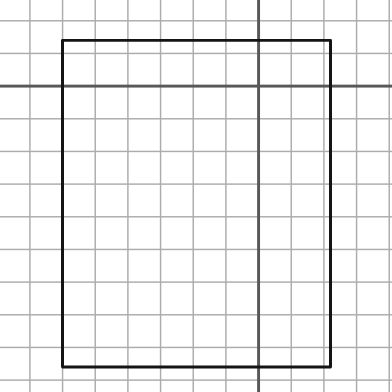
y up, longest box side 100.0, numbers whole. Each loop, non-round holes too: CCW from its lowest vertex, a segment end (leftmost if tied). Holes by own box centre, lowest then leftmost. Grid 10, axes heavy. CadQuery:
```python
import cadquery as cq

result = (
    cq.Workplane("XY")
    .moveTo(-60.0, -86.0)
    .lineTo(22.0, -86.0)
    .lineTo(22.0, 14.0)
    .lineTo(-60.0, 14.0)
    .close()
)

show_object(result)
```